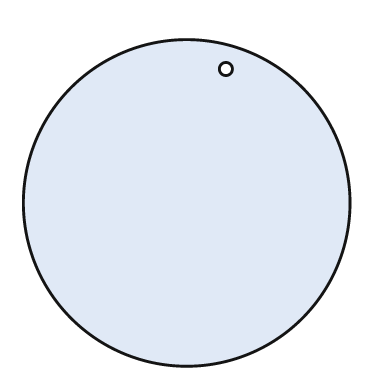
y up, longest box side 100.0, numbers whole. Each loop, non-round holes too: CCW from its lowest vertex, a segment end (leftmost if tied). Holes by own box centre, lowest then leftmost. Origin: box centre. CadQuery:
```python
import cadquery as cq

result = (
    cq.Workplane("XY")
    .moveTo(0.0, 0.0)
    .circle(50.0)
    .moveTo(12.0, 41.0)
    .circle(2.0)
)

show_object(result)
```